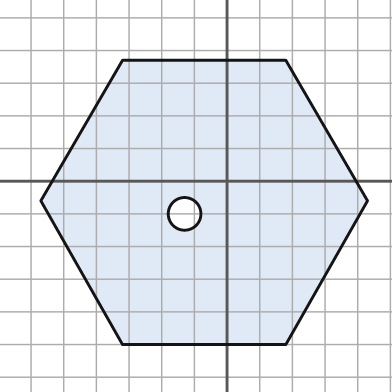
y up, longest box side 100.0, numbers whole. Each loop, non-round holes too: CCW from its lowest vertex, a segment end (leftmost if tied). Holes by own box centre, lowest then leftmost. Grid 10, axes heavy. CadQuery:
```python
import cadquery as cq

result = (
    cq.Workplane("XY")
    .moveTo(-32.0, -50.0)
    .lineTo(18.0, -50.0)
    .lineTo(43.0, -6.0)
    .lineTo(18.0, 37.0)
    .lineTo(-32.0, 37.0)
    .lineTo(-57.0, -6.0)
    .close()
    .moveTo(-13.0, -10.0)
    .circle(5.0)
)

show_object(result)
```